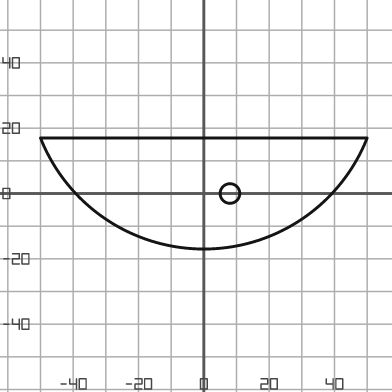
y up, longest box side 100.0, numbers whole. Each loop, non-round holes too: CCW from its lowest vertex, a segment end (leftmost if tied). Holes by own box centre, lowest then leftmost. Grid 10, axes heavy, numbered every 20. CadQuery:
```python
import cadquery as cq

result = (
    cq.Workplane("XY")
    .moveTo(-50.0, 17.0)
    .threePointArc((0.0, -17.0), (50.0, 17.0))
    .close()
    .moveTo(8.0, 0.0)
    .circle(3.0)
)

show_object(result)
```